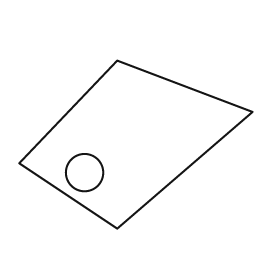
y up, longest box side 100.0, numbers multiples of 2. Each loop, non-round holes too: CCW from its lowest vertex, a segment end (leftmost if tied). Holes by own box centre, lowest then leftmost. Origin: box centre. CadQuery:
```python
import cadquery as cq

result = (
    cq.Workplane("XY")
    .moveTo(-8.0, -36.0)
    .lineTo(50.0, 14.0)
    .lineTo(-8.0, 36.0)
    .lineTo(-50.0, -8.0)
    .close()
    .moveTo(-22.0, -12.0)
    .circle(8.0)
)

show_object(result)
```